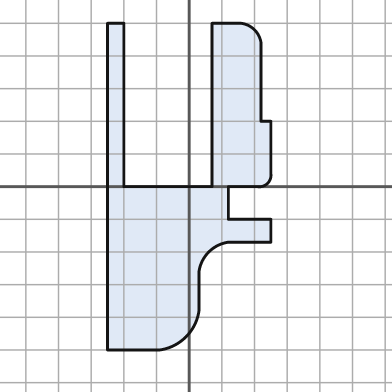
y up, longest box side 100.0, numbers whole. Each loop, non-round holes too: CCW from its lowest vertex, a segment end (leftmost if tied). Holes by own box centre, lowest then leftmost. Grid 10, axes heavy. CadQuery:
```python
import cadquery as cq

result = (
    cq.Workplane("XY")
    .moveTo(-25.0, -50.0)
    .lineTo(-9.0, -50.0)
    .threePointArc((-1.0, -46.0), (3.0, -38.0))
    .lineTo(3.0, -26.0)
    .threePointArc((6.0, -20.0), (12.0, -17.0))
    .lineTo(25.0, -17.0)
    .lineTo(25.0, -10.0)
    .lineTo(12.0, -10.0)
    .lineTo(12.0, 0.0)
    .lineTo(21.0, 0.0)
    .threePointArc((24.0, 1.0), (25.0, 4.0))
    .lineTo(25.0, 20.0)
    .lineTo(22.0, 20.0)
    .lineTo(22.0, 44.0)
    .threePointArc((20.0, 48.0), (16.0, 50.0))
    .lineTo(7.0, 50.0)
    .lineTo(7.0, 0.0)
    .lineTo(-20.0, 0.0)
    .lineTo(-20.0, 50.0)
    .lineTo(-25.0, 50.0)
    .close()
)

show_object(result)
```